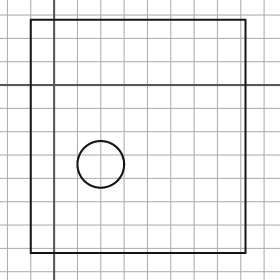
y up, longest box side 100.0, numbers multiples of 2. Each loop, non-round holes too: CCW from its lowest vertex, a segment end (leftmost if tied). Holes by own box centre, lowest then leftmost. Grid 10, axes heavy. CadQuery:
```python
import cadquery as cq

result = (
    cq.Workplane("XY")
    .moveTo(-10.0, -72.0)
    .lineTo(82.0, -72.0)
    .lineTo(82.0, 28.0)
    .lineTo(-10.0, 28.0)
    .close()
    .moveTo(20.0, -34.0)
    .circle(10.0)
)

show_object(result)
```